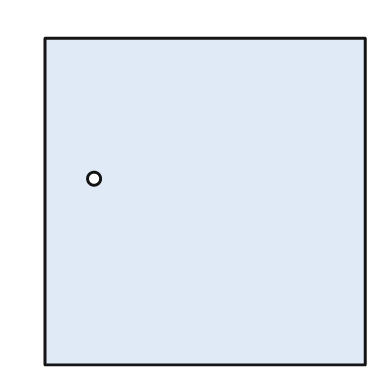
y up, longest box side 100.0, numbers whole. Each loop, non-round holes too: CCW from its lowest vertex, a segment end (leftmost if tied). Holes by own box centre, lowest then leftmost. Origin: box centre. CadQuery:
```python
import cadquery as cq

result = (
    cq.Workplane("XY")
    .moveTo(-49.0, -50.0)
    .lineTo(49.0, -50.0)
    .lineTo(49.0, 50.0)
    .lineTo(-49.0, 50.0)
    .close()
    .moveTo(-34.0, 7.0)
    .circle(2.0)
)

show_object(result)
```